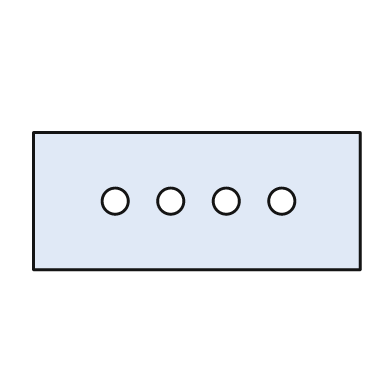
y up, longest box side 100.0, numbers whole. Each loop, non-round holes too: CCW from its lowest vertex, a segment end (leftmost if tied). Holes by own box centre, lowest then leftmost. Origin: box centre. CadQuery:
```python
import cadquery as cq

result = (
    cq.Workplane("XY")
    .moveTo(-50.0, -21.0)
    .lineTo(50.0, -21.0)
    .lineTo(50.0, 21.0)
    .lineTo(-50.0, 21.0)
    .close()
    .moveTo(-25.0, 0.0)
    .circle(4.0)
    .moveTo(-8.0, 0.0)
    .circle(4.0)
    .moveTo(9.0, 0.0)
    .circle(4.0)
    .moveTo(26.0, 0.0)
    .circle(4.0)
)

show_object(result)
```